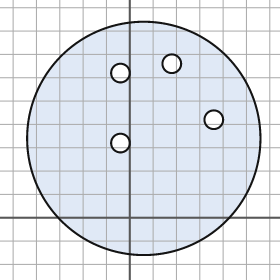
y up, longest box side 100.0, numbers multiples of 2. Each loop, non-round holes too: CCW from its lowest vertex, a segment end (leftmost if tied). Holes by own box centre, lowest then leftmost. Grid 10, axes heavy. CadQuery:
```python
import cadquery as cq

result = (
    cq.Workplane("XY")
    .moveTo(6.0, 34.0)
    .circle(50.0)
    .moveTo(-4.0, 32.0)
    .circle(4.0)
    .moveTo(36.0, 42.0)
    .circle(4.0)
    .moveTo(-4.0, 62.0)
    .circle(4.0)
    .moveTo(18.0, 66.0)
    .circle(4.0)
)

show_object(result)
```